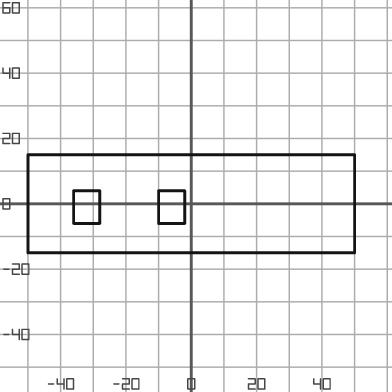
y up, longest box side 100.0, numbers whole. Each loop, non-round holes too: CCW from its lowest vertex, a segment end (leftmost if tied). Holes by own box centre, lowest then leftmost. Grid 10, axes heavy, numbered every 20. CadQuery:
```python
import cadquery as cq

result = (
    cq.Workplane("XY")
    .moveTo(-50.0, -15.0)
    .lineTo(50.0, -15.0)
    .lineTo(50.0, 15.0)
    .lineTo(-50.0, 15.0)
    .close()
    .moveTo(-36.0, -6.0)
    .lineTo(-28.0, -6.0)
    .lineTo(-28.0, 4.0)
    .lineTo(-36.0, 4.0)
    .close()
    .moveTo(-10.0, -6.0)
    .lineTo(-2.0, -6.0)
    .lineTo(-2.0, 4.0)
    .lineTo(-10.0, 4.0)
    .close()
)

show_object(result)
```